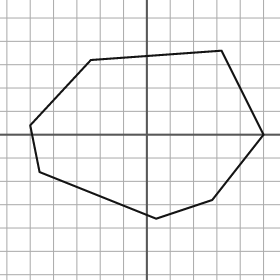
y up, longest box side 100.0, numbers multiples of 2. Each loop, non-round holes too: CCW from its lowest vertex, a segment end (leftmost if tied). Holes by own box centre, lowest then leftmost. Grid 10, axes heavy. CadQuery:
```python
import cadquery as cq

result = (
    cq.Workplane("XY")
    .moveTo(4.0, -36.0)
    .lineTo(28.0, -28.0)
    .lineTo(50.0, 0.0)
    .lineTo(32.0, 36.0)
    .lineTo(-24.0, 32.0)
    .lineTo(-50.0, 4.0)
    .lineTo(-46.0, -16.0)
    .close()
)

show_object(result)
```